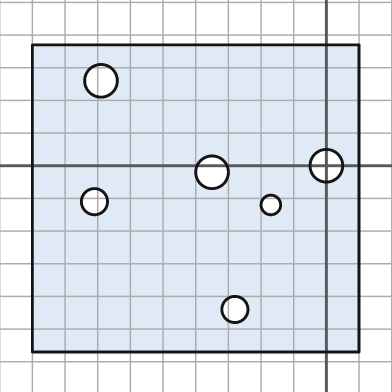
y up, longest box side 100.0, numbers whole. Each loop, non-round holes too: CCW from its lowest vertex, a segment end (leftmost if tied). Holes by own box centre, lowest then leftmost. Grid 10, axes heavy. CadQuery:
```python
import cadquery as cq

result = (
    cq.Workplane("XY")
    .moveTo(-90.0, -57.0)
    .lineTo(10.0, -57.0)
    .lineTo(10.0, 37.0)
    .lineTo(-90.0, 37.0)
    .close()
    .moveTo(-28.0, -44.0)
    .circle(4.0)
    .moveTo(-17.0, -12.0)
    .circle(3.0)
    .moveTo(-71.0, -11.0)
    .circle(4.0)
    .moveTo(-35.0, -2.0)
    .circle(5.0)
    .moveTo(0.0, 0.0)
    .circle(5.0)
    .moveTo(-69.0, 26.0)
    .circle(5.0)
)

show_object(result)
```